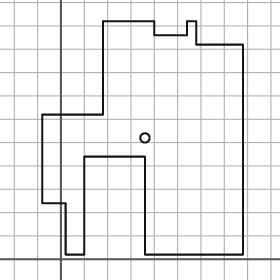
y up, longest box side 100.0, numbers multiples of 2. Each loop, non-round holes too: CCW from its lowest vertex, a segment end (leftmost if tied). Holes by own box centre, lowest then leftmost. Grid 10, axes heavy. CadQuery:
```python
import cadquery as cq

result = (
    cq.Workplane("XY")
    .moveTo(2.0, 2.0)
    .lineTo(10.0, 2.0)
    .lineTo(10.0, 44.0)
    .lineTo(36.0, 44.0)
    .lineTo(36.0, 2.0)
    .lineTo(78.0, 2.0)
    .lineTo(78.0, 92.0)
    .lineTo(58.0, 92.0)
    .lineTo(58.0, 102.0)
    .lineTo(54.0, 102.0)
    .lineTo(54.0, 96.0)
    .lineTo(40.0, 96.0)
    .lineTo(40.0, 102.0)
    .lineTo(18.0, 102.0)
    .lineTo(18.0, 62.0)
    .lineTo(-8.0, 62.0)
    .lineTo(-8.0, 24.0)
    .lineTo(2.0, 24.0)
    .close()
    .moveTo(36.0, 52.0)
    .circle(2.0)
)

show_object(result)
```